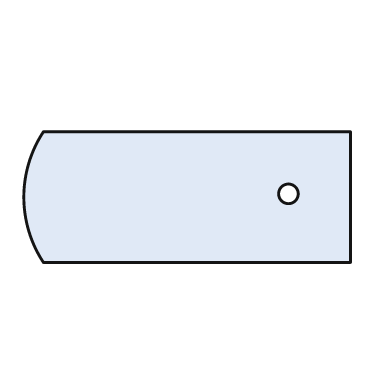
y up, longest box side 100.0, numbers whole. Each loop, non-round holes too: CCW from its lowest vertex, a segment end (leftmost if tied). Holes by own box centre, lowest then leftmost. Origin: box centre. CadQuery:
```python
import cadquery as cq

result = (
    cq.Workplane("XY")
    .moveTo(-44.0, -20.0)
    .lineTo(50.0, -20.0)
    .lineTo(50.0, 20.0)
    .lineTo(-44.0, 20.0)
    .threePointArc((-50.0, 0.0), (-44.0, -20.0))
    .close()
    .moveTo(31.0, 1.0)
    .circle(3.0)
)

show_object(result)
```